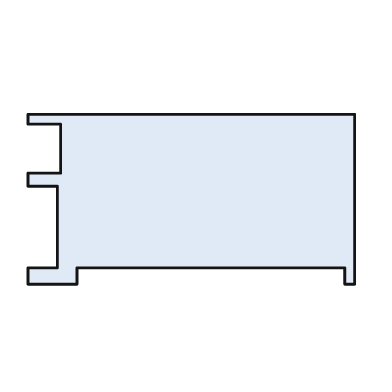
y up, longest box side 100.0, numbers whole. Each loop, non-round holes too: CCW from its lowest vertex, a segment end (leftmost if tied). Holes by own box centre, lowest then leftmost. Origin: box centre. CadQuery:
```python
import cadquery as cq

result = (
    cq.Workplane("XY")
    .moveTo(-50.0, -26.0)
    .lineTo(-35.0, -26.0)
    .lineTo(-35.0, -21.0)
    .lineTo(47.0, -21.0)
    .lineTo(47.0, -26.0)
    .lineTo(50.0, -26.0)
    .lineTo(50.0, 26.0)
    .lineTo(-50.0, 26.0)
    .lineTo(-50.0, 23.0)
    .lineTo(-40.0, 23.0)
    .lineTo(-40.0, 8.0)
    .lineTo(-50.0, 8.0)
    .lineTo(-50.0, 4.0)
    .lineTo(-41.0, 4.0)
    .lineTo(-41.0, -21.0)
    .lineTo(-50.0, -21.0)
    .close()
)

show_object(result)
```